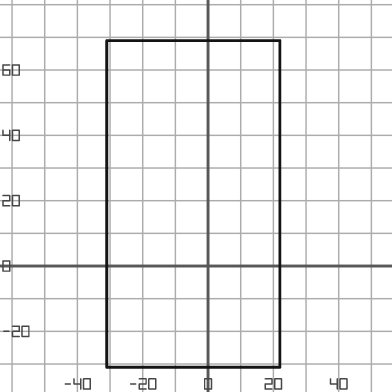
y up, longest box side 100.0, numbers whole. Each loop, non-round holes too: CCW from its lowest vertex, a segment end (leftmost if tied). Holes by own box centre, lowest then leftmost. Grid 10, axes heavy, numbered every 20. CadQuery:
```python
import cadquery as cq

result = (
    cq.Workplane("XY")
    .moveTo(-31.0, -31.0)
    .lineTo(22.0, -31.0)
    .lineTo(22.0, 69.0)
    .lineTo(-31.0, 69.0)
    .close()
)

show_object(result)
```